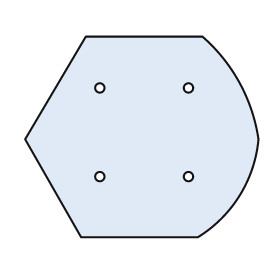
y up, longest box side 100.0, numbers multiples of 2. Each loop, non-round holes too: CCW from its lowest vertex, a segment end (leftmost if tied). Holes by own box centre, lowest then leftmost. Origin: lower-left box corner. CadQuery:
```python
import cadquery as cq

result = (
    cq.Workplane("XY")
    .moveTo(24.0, 0.0)
    .lineTo(74.0, 0.0)
    .threePointArc((92.0, 18.0), (100.0, 42.0))
    .threePointArc((92.0, 66.0), (76.0, 86.0))
    .lineTo(26.0, 86.0)
    .lineTo(0.0, 42.0)
    .close()
    .moveTo(32.0, 26.0)
    .circle(2.0)
    .moveTo(70.0, 26.0)
    .circle(2.0)
    .moveTo(32.0, 64.0)
    .circle(2.0)
    .moveTo(70.0, 64.0)
    .circle(2.0)
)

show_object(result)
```